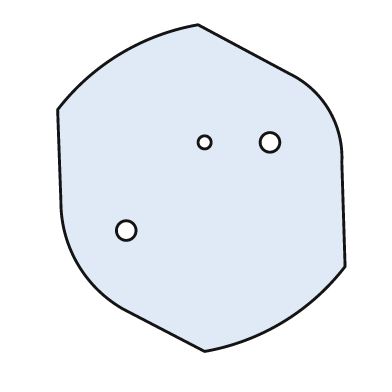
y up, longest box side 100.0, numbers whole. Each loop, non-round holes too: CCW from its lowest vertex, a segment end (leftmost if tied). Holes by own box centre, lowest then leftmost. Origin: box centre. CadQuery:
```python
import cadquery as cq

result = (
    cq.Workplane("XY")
    .moveTo(1.0, -50.0)
    .threePointArc((25.0, -41.0), (44.0, -24.0))
    .lineTo(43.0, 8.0)
    .threePointArc((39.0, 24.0), (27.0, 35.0))
    .lineTo(-1.0, 50.0)
    .threePointArc((-25.0, 41.0), (-44.0, 24.0))
    .lineTo(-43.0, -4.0)
    .threePointArc((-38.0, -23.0), (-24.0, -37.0))
    .close()
    .moveTo(-23.0, -13.0)
    .circle(3.0)
    .moveTo(1.0, 14.0)
    .circle(2.0)
    .moveTo(21.0, 14.0)
    .circle(3.0)
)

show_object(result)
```